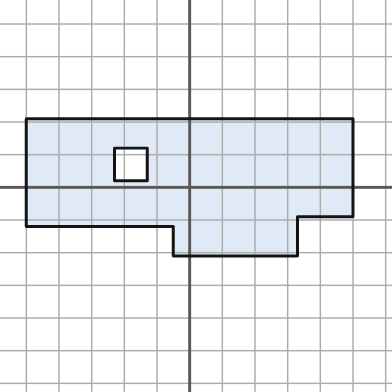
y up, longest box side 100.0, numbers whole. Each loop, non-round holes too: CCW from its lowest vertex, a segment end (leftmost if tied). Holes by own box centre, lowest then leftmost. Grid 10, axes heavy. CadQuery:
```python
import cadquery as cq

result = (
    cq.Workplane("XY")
    .moveTo(-5.0, -21.0)
    .lineTo(33.0, -21.0)
    .lineTo(33.0, -9.0)
    .lineTo(50.0, -9.0)
    .lineTo(50.0, 21.0)
    .lineTo(-50.0, 21.0)
    .lineTo(-50.0, -12.0)
    .lineTo(-5.0, -12.0)
    .close()
    .moveTo(-23.0, 2.0)
    .lineTo(-13.0, 2.0)
    .lineTo(-13.0, 12.0)
    .lineTo(-23.0, 12.0)
    .close()
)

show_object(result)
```